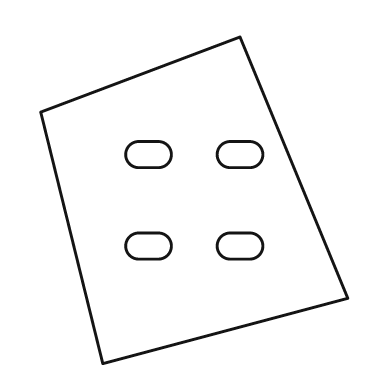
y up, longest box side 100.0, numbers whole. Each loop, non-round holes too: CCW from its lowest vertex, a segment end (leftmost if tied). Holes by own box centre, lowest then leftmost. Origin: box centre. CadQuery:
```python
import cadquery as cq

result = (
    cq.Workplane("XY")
    .moveTo(-28.0, -50.0)
    .lineTo(47.0, -30.0)
    .lineTo(14.0, 50.0)
    .lineTo(-47.0, 27.0)
    .close()
    .moveTo(-17.0, -18.0)
    .lineTo(-11.0, -18.0)
    .threePointArc((-7.0, -14.0), (-11.0, -10.0))
    .lineTo(-17.0, -10.0)
    .threePointArc((-21.0, -14.0), (-17.0, -18.0))
    .close()
    .moveTo(11.0, -18.0)
    .lineTo(17.0, -18.0)
    .threePointArc((21.0, -14.0), (17.0, -10.0))
    .lineTo(11.0, -10.0)
    .threePointArc((7.0, -14.0), (11.0, -18.0))
    .close()
    .moveTo(-17.0, 10.0)
    .lineTo(-11.0, 10.0)
    .threePointArc((-7.0, 14.0), (-11.0, 18.0))
    .lineTo(-17.0, 18.0)
    .threePointArc((-21.0, 14.0), (-17.0, 10.0))
    .close()
    .moveTo(11.0, 10.0)
    .lineTo(17.0, 10.0)
    .threePointArc((21.0, 14.0), (17.0, 18.0))
    .lineTo(11.0, 18.0)
    .threePointArc((7.0, 14.0), (11.0, 10.0))
    .close()
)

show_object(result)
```